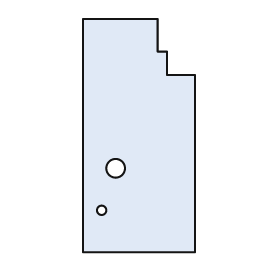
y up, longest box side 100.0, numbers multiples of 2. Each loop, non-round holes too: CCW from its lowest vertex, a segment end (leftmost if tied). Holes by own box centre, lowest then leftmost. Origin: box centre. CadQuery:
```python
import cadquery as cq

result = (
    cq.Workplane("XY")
    .moveTo(-24.0, -50.0)
    .lineTo(24.0, -50.0)
    .lineTo(24.0, 26.0)
    .lineTo(12.0, 26.0)
    .lineTo(12.0, 36.0)
    .lineTo(8.0, 36.0)
    .lineTo(8.0, 50.0)
    .lineTo(-24.0, 50.0)
    .close()
    .moveTo(-16.0, -32.0)
    .circle(2.0)
    .moveTo(-10.0, -14.0)
    .circle(4.0)
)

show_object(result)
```